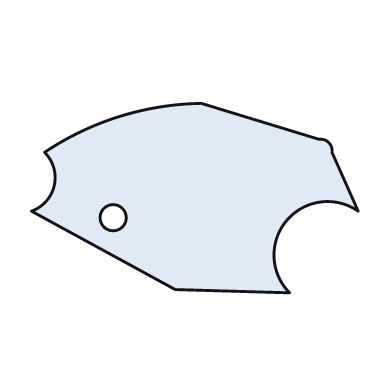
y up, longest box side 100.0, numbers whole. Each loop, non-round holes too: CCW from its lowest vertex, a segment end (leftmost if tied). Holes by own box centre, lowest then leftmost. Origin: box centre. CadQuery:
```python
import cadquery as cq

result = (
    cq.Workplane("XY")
    .moveTo(29.0, -29.0)
    .threePointArc((28.0, -7.0), (50.0, -4.0))
    .lineTo(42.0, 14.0)
    .threePointArc((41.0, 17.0), (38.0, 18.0))
    .lineTo(2.0, 29.0)
    .threePointArc((-23.0, 25.0), (-46.0, 14.0))
    .threePointArc((-43.0, 4.0), (-50.0, -4.0))
    .lineTo(-6.0, -28.0)
    .close()
    .moveTo(-25.0, -6.0)
    .circle(4.0)
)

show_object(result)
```